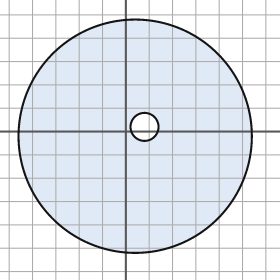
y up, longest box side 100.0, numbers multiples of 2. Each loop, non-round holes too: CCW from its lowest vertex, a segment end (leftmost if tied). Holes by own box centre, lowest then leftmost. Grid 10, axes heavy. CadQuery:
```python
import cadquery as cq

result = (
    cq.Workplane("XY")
    .moveTo(4.0, -2.0)
    .circle(50.0)
    .moveTo(8.0, 2.0)
    .circle(6.0)
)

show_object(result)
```